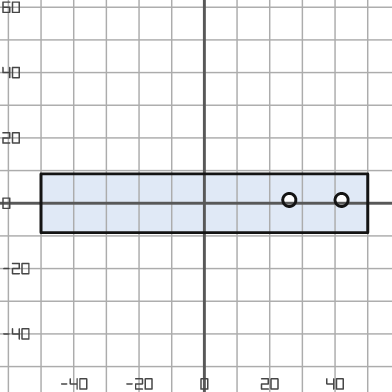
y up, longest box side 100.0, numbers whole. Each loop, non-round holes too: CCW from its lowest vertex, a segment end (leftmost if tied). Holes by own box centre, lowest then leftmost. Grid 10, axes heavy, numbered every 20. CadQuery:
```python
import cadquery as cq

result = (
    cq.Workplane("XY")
    .moveTo(-50.0, -9.0)
    .lineTo(50.0, -9.0)
    .lineTo(50.0, 9.0)
    .lineTo(-50.0, 9.0)
    .close()
    .moveTo(26.0, 1.0)
    .circle(2.0)
    .moveTo(42.0, 1.0)
    .circle(2.0)
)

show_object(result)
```